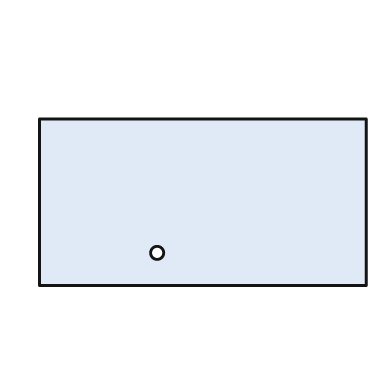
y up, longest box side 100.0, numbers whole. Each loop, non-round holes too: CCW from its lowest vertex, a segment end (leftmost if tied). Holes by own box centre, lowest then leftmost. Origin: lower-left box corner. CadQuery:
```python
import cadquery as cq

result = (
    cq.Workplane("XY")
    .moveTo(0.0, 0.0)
    .lineTo(100.0, 0.0)
    .lineTo(100.0, 51.0)
    .lineTo(0.0, 51.0)
    .close()
    .moveTo(36.0, 10.0)
    .circle(2.0)
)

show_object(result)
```